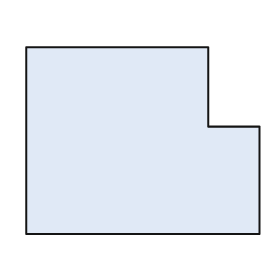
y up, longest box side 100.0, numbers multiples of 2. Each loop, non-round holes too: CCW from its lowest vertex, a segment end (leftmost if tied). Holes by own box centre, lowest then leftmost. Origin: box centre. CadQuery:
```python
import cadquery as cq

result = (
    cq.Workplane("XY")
    .moveTo(-50.0, -40.0)
    .lineTo(50.0, -40.0)
    .lineTo(50.0, 6.0)
    .lineTo(28.0, 6.0)
    .lineTo(28.0, 40.0)
    .lineTo(-50.0, 40.0)
    .close()
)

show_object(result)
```